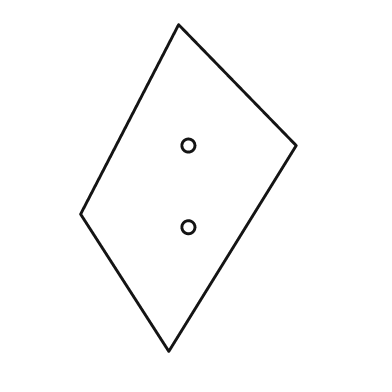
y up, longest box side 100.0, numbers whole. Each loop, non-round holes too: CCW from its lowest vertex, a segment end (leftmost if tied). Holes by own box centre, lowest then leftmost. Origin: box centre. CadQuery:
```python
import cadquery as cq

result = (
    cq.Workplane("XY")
    .moveTo(-6.0, -50.0)
    .lineTo(33.0, 13.0)
    .lineTo(-3.0, 50.0)
    .lineTo(-33.0, -8.0)
    .close()
    .moveTo(0.0, -12.0)
    .circle(2.0)
    .moveTo(0.0, 13.0)
    .circle(2.0)
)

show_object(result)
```